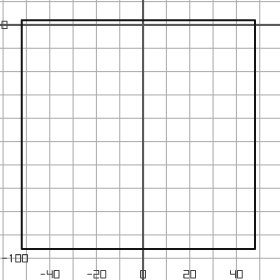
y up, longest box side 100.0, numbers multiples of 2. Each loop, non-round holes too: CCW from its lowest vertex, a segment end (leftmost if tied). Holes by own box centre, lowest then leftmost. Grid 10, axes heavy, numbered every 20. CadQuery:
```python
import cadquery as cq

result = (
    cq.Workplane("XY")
    .moveTo(-52.0, -96.0)
    .lineTo(48.0, -96.0)
    .lineTo(48.0, 2.0)
    .lineTo(-52.0, 2.0)
    .close()
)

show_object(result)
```